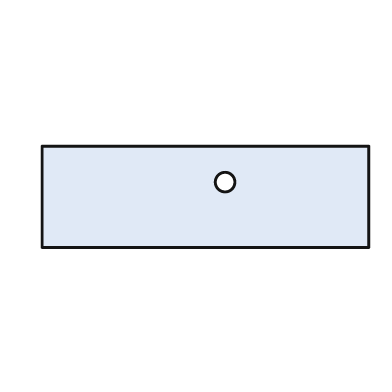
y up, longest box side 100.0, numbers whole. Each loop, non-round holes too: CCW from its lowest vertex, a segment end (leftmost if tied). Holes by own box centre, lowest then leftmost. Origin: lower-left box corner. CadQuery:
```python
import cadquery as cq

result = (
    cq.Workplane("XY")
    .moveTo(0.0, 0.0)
    .lineTo(100.0, 0.0)
    .lineTo(100.0, 31.0)
    .lineTo(0.0, 31.0)
    .close()
    .moveTo(56.0, 20.0)
    .circle(3.0)
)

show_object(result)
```